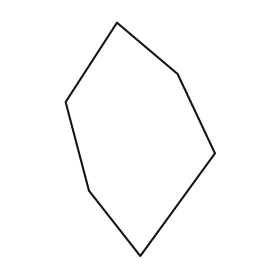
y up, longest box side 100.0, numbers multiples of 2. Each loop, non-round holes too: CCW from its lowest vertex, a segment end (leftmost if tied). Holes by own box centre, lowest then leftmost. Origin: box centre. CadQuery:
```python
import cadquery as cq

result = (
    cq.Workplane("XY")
    .moveTo(0.0, -50.0)
    .lineTo(32.0, -6.0)
    .lineTo(16.0, 28.0)
    .lineTo(-10.0, 50.0)
    .lineTo(-32.0, 16.0)
    .lineTo(-22.0, -22.0)
    .close()
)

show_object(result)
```